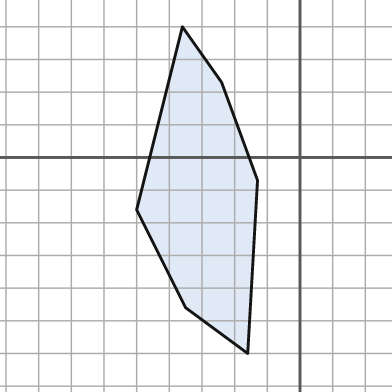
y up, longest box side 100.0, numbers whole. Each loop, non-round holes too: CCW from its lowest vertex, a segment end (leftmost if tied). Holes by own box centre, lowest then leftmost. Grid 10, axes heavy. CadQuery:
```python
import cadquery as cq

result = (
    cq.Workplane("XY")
    .moveTo(-16.0, -60.0)
    .lineTo(-13.0, -7.0)
    .lineTo(-24.0, 23.0)
    .lineTo(-36.0, 40.0)
    .lineTo(-50.0, -16.0)
    .lineTo(-35.0, -46.0)
    .close()
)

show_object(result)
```